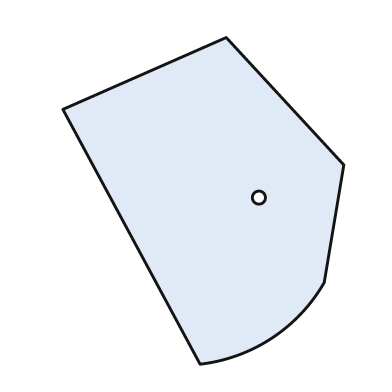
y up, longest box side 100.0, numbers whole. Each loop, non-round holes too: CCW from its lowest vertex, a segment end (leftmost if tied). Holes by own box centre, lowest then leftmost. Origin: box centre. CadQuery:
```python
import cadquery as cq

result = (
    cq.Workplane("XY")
    .moveTo(-1.0, -50.0)
    .threePointArc((21.0, -42.0), (37.0, -25.0))
    .lineTo(43.0, 11.0)
    .lineTo(7.0, 50.0)
    .lineTo(-43.0, 28.0)
    .close()
    .moveTo(17.0, 1.0)
    .circle(2.0)
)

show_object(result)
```